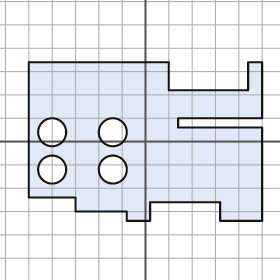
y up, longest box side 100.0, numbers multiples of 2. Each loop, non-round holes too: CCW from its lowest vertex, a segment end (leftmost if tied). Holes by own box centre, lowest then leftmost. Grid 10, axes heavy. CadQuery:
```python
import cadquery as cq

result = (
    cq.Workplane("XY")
    .moveTo(-8.0, -34.0)
    .lineTo(2.0, -34.0)
    .lineTo(2.0, -26.0)
    .lineTo(32.0, -26.0)
    .lineTo(32.0, -34.0)
    .lineTo(50.0, -34.0)
    .lineTo(50.0, 6.0)
    .lineTo(14.0, 6.0)
    .lineTo(14.0, 10.0)
    .lineTo(50.0, 10.0)
    .lineTo(50.0, 34.0)
    .lineTo(44.0, 34.0)
    .lineTo(44.0, 22.0)
    .lineTo(10.0, 22.0)
    .lineTo(10.0, 34.0)
    .lineTo(-50.0, 34.0)
    .lineTo(-50.0, -24.0)
    .lineTo(-30.0, -24.0)
    .lineTo(-30.0, -30.0)
    .lineTo(-8.0, -30.0)
    .close()
    .moveTo(-40.0, -12.0)
    .circle(6.0)
    .moveTo(-14.0, -12.0)
    .circle(6.0)
    .moveTo(-40.0, 4.0)
    .circle(6.0)
    .moveTo(-14.0, 4.0)
    .circle(6.0)
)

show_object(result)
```